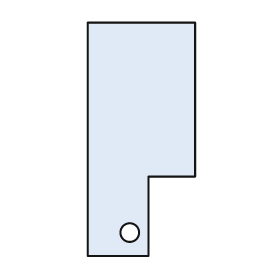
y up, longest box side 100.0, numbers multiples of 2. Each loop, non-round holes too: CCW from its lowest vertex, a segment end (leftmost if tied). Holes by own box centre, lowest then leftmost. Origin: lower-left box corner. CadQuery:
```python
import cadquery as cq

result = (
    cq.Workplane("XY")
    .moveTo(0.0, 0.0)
    .lineTo(26.0, 0.0)
    .lineTo(26.0, 34.0)
    .lineTo(46.0, 34.0)
    .lineTo(46.0, 100.0)
    .lineTo(0.0, 100.0)
    .close()
    .moveTo(18.0, 10.0)
    .circle(4.0)
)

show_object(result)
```